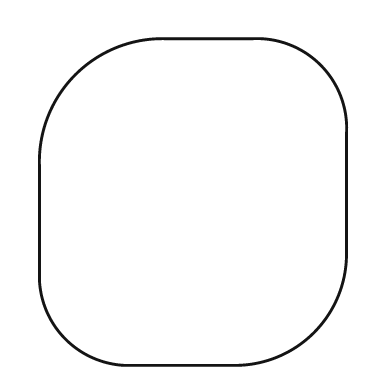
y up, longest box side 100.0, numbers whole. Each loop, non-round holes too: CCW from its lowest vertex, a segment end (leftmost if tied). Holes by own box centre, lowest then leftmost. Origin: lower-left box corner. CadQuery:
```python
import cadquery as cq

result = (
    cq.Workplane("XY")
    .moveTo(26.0, 0.0)
    .lineTo(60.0, 0.0)
    .threePointArc((84.0, 10.0), (94.0, 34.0))
    .lineTo(94.0, 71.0)
    .threePointArc((86.0, 92.0), (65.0, 100.0))
    .lineTo(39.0, 100.0)
    .threePointArc((11.0, 89.0), (0.0, 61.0))
    .lineTo(0.0, 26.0)
    .threePointArc((8.0, 8.0), (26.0, 0.0))
    .close()
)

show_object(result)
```